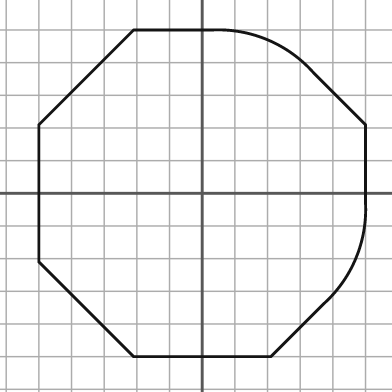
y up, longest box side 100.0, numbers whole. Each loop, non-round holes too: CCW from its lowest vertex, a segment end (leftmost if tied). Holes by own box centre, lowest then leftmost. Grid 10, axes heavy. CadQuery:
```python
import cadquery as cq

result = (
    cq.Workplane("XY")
    .moveTo(-21.0, -50.0)
    .lineTo(21.0, -50.0)
    .lineTo(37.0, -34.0)
    .threePointArc((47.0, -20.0), (50.0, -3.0))
    .lineTo(50.0, 21.0)
    .lineTo(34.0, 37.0)
    .threePointArc((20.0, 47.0), (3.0, 50.0))
    .lineTo(-21.0, 50.0)
    .lineTo(-50.0, 21.0)
    .lineTo(-50.0, -21.0)
    .close()
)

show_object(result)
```